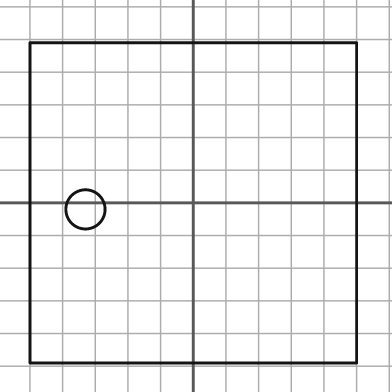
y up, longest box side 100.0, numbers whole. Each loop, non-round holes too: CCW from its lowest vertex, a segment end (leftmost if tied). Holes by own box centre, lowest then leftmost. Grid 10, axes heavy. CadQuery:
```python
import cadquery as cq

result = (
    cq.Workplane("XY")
    .moveTo(-50.0, -49.0)
    .lineTo(50.0, -49.0)
    .lineTo(50.0, 49.0)
    .lineTo(-50.0, 49.0)
    .close()
    .moveTo(-33.0, -2.0)
    .circle(6.0)
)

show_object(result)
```